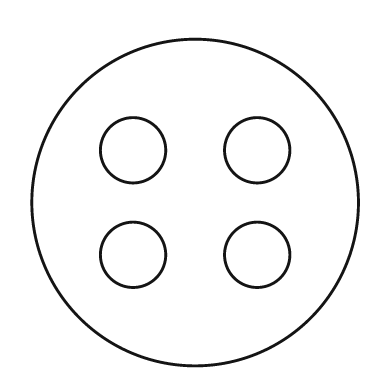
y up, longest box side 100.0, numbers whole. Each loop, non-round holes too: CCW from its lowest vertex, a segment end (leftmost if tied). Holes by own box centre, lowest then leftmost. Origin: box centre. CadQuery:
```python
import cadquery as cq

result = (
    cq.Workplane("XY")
    .moveTo(0.0, 0.0)
    .circle(50.0)
    .moveTo(-19.0, -16.0)
    .circle(10.0)
    .moveTo(19.0, -16.0)
    .circle(10.0)
    .moveTo(-19.0, 16.0)
    .circle(10.0)
    .moveTo(19.0, 16.0)
    .circle(10.0)
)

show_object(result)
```